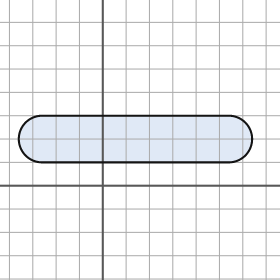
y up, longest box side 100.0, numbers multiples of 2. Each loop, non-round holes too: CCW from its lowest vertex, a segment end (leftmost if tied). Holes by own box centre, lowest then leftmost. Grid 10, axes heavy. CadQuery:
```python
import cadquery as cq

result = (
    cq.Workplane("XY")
    .moveTo(-26.0, 10.0)
    .lineTo(54.0, 10.0)
    .threePointArc((64.0, 20.0), (54.0, 30.0))
    .lineTo(-26.0, 30.0)
    .threePointArc((-36.0, 20.0), (-26.0, 10.0))
    .close()
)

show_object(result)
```